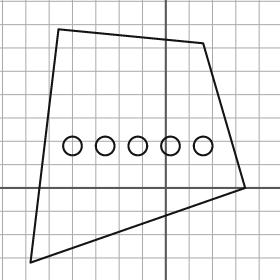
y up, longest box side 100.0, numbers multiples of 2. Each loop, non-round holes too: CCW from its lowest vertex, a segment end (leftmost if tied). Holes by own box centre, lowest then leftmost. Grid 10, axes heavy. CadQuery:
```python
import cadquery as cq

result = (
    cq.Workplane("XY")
    .moveTo(-58.0, -32.0)
    .lineTo(34.0, 0.0)
    .lineTo(16.0, 62.0)
    .lineTo(-46.0, 68.0)
    .close()
    .moveTo(-40.0, 18.0)
    .circle(4.0)
    .moveTo(-26.0, 18.0)
    .circle(4.0)
    .moveTo(-12.0, 18.0)
    .circle(4.0)
    .moveTo(2.0, 18.0)
    .circle(4.0)
    .moveTo(16.0, 18.0)
    .circle(4.0)
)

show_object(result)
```